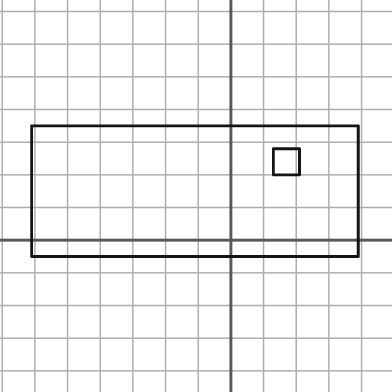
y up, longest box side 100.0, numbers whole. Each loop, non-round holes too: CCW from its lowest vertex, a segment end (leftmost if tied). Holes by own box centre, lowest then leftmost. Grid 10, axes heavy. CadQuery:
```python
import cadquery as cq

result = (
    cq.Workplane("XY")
    .moveTo(-61.0, -5.0)
    .lineTo(39.0, -5.0)
    .lineTo(39.0, 35.0)
    .lineTo(-61.0, 35.0)
    .close()
    .moveTo(13.0, 20.0)
    .lineTo(21.0, 20.0)
    .lineTo(21.0, 28.0)
    .lineTo(13.0, 28.0)
    .close()
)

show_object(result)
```